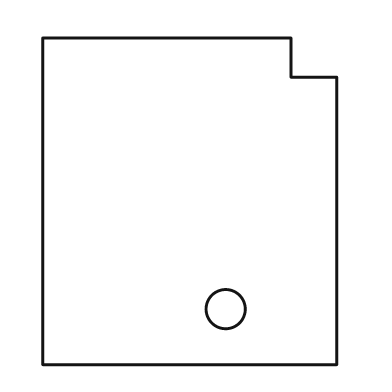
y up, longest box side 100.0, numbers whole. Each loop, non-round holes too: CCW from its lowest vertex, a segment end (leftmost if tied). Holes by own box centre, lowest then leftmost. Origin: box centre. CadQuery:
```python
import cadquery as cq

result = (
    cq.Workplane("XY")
    .moveTo(-45.0, -50.0)
    .lineTo(45.0, -50.0)
    .lineTo(45.0, 38.0)
    .lineTo(31.0, 38.0)
    .lineTo(31.0, 50.0)
    .lineTo(-45.0, 50.0)
    .close()
    .moveTo(11.0, -33.0)
    .circle(6.0)
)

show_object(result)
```